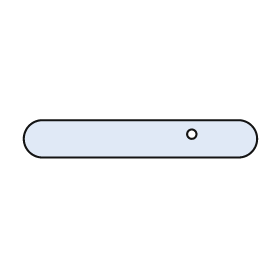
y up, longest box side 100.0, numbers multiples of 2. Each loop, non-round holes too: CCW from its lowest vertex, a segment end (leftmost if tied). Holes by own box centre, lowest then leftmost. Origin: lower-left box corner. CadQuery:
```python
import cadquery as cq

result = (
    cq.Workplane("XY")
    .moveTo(8.0, 0.0)
    .lineTo(92.0, 0.0)
    .threePointArc((100.0, 8.0), (92.0, 16.0))
    .lineTo(8.0, 16.0)
    .threePointArc((0.0, 8.0), (8.0, 0.0))
    .close()
    .moveTo(72.0, 10.0)
    .circle(2.0)
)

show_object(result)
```